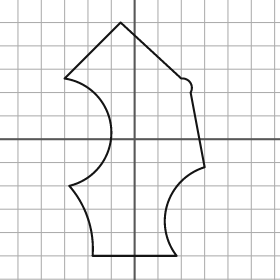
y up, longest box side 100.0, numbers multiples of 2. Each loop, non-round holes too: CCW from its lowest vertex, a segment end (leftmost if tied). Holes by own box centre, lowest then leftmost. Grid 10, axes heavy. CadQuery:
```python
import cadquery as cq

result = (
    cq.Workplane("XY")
    .moveTo(-18.0, -50.0)
    .lineTo(18.0, -50.0)
    .threePointArc((14.0, -28.0), (30.0, -12.0))
    .lineTo(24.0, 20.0)
    .threePointArc((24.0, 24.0), (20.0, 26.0))
    .lineTo(-6.0, 50.0)
    .lineTo(-30.0, 26.0)
    .threePointArc((-10.0, 4.0), (-28.0, -20.0))
    .threePointArc((-20.0, -34.0), (-18.0, -50.0))
    .close()
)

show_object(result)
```